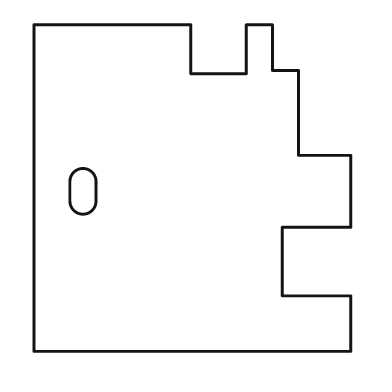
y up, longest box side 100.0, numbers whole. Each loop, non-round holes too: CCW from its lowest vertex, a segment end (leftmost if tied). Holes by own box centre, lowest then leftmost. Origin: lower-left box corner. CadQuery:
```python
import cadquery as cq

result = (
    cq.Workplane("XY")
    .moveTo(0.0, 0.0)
    .lineTo(97.0, 0.0)
    .lineTo(97.0, 17.0)
    .lineTo(76.0, 17.0)
    .lineTo(76.0, 38.0)
    .lineTo(97.0, 38.0)
    .lineTo(97.0, 60.0)
    .lineTo(81.0, 60.0)
    .lineTo(81.0, 86.0)
    .lineTo(73.0, 86.0)
    .lineTo(73.0, 100.0)
    .lineTo(65.0, 100.0)
    .lineTo(65.0, 85.0)
    .lineTo(48.0, 85.0)
    .lineTo(48.0, 100.0)
    .lineTo(0.0, 100.0)
    .close()
    .moveTo(11.0, 46.0)
    .threePointArc((15.0, 42.0), (19.0, 46.0))
    .lineTo(19.0, 52.0)
    .threePointArc((15.0, 56.0), (11.0, 52.0))
    .close()
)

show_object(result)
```